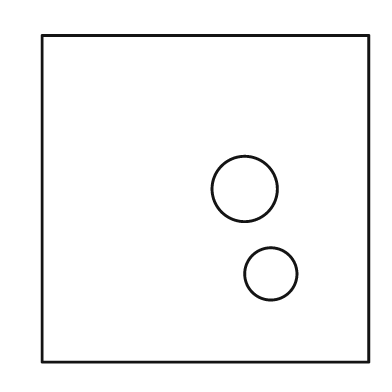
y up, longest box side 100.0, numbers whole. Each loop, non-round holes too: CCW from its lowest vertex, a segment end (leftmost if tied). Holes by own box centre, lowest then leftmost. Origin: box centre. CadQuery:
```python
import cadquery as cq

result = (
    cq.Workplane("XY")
    .moveTo(-50.0, -50.0)
    .lineTo(50.0, -50.0)
    .lineTo(50.0, 50.0)
    .lineTo(-50.0, 50.0)
    .close()
    .moveTo(20.0, -23.0)
    .circle(8.0)
    .moveTo(12.0, 3.0)
    .circle(10.0)
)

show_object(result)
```